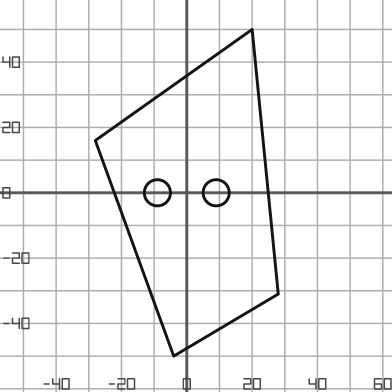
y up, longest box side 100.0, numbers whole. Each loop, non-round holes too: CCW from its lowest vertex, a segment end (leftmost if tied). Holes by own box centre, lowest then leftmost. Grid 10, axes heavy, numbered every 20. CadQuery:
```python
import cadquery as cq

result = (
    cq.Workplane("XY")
    .moveTo(-4.0, -50.0)
    .lineTo(28.0, -31.0)
    .lineTo(20.0, 50.0)
    .lineTo(-28.0, 16.0)
    .close()
    .moveTo(-9.0, 0.0)
    .circle(4.0)
    .moveTo(9.0, 0.0)
    .circle(4.0)
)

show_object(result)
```